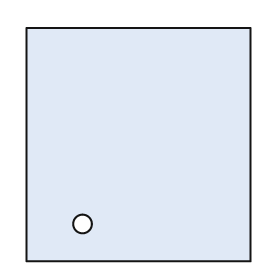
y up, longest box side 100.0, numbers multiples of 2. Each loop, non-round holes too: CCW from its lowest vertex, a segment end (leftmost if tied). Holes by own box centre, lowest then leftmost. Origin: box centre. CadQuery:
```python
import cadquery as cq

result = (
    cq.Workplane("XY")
    .moveTo(-48.0, -50.0)
    .lineTo(48.0, -50.0)
    .lineTo(48.0, 50.0)
    .lineTo(-48.0, 50.0)
    .close()
    .moveTo(-24.0, -34.0)
    .circle(4.0)
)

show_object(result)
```